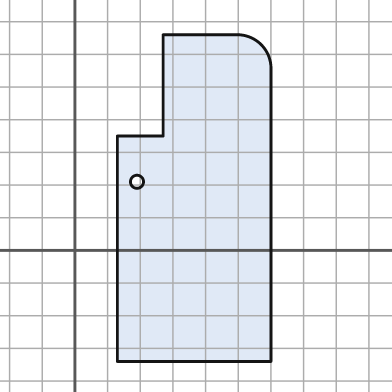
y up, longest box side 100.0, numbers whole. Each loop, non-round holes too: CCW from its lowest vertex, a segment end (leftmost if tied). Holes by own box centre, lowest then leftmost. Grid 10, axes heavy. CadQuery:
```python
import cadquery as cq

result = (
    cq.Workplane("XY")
    .moveTo(13.0, -34.0)
    .lineTo(60.0, -34.0)
    .lineTo(60.0, 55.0)
    .threePointArc((57.0, 63.0), (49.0, 66.0))
    .lineTo(27.0, 66.0)
    .lineTo(27.0, 35.0)
    .lineTo(13.0, 35.0)
    .close()
    .moveTo(19.0, 21.0)
    .circle(2.0)
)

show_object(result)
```